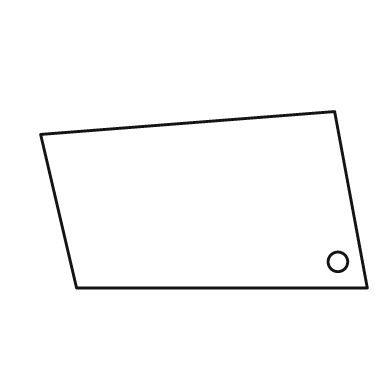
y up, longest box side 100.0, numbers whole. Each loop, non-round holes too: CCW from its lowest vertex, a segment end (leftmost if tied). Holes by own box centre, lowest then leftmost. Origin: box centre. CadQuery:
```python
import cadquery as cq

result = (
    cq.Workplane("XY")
    .moveTo(-39.0, -27.0)
    .lineTo(50.0, -27.0)
    .lineTo(40.0, 27.0)
    .lineTo(-50.0, 20.0)
    .close()
    .moveTo(41.0, -19.0)
    .circle(3.0)
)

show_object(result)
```